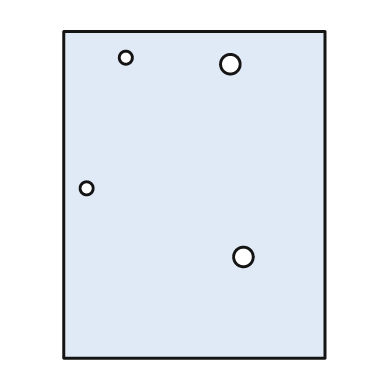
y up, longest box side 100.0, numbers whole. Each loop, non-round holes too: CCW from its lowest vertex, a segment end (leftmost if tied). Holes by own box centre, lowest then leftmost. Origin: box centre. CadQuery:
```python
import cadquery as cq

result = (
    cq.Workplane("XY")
    .moveTo(-40.0, -50.0)
    .lineTo(40.0, -50.0)
    .lineTo(40.0, 50.0)
    .lineTo(-40.0, 50.0)
    .close()
    .moveTo(15.0, -19.0)
    .circle(3.0)
    .moveTo(-33.0, 2.0)
    .circle(2.0)
    .moveTo(11.0, 40.0)
    .circle(3.0)
    .moveTo(-21.0, 42.0)
    .circle(2.0)
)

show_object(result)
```